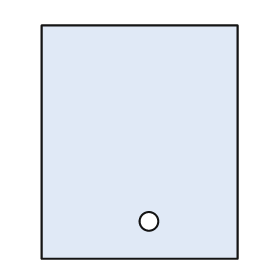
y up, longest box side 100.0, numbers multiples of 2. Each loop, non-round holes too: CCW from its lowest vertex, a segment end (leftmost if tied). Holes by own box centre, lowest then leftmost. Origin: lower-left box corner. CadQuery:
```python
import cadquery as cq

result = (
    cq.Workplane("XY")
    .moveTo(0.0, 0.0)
    .lineTo(84.0, 0.0)
    .lineTo(84.0, 100.0)
    .lineTo(0.0, 100.0)
    .close()
    .moveTo(46.0, 16.0)
    .circle(4.0)
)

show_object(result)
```